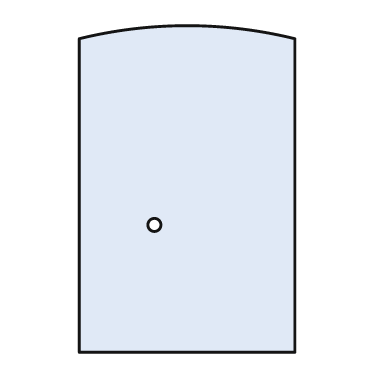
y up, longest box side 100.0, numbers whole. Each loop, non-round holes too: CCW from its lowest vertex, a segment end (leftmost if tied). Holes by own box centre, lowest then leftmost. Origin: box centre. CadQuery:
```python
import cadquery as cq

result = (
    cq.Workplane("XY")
    .moveTo(-33.0, -50.0)
    .lineTo(33.0, -50.0)
    .lineTo(33.0, 46.0)
    .threePointArc((0.0, 50.0), (-33.0, 46.0))
    .close()
    .moveTo(-10.0, -11.0)
    .circle(2.0)
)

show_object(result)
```